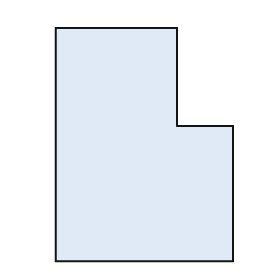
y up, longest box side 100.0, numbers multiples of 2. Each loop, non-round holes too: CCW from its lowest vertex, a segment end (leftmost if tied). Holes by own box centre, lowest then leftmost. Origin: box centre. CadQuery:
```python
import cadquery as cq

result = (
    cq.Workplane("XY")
    .moveTo(-38.0, -50.0)
    .lineTo(38.0, -50.0)
    .lineTo(38.0, 8.0)
    .lineTo(14.0, 8.0)
    .lineTo(14.0, 50.0)
    .lineTo(-38.0, 50.0)
    .close()
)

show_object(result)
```